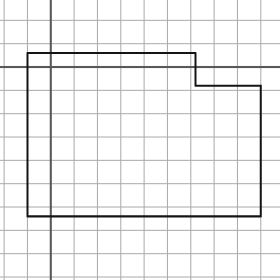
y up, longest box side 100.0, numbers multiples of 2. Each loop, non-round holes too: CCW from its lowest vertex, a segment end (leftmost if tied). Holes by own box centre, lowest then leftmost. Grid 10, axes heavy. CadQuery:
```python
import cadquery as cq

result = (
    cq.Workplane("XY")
    .moveTo(-10.0, -64.0)
    .lineTo(90.0, -64.0)
    .lineTo(90.0, -8.0)
    .lineTo(62.0, -8.0)
    .lineTo(62.0, 6.0)
    .lineTo(-10.0, 6.0)
    .close()
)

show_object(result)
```